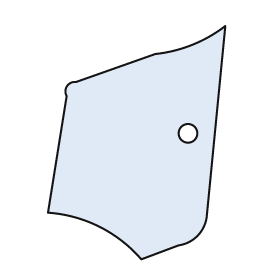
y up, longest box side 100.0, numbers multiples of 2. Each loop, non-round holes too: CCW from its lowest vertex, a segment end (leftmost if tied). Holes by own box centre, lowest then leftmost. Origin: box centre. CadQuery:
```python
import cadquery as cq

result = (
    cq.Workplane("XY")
    .moveTo(2.0, -50.0)
    .lineTo(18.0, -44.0)
    .threePointArc((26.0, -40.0), (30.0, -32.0))
    .lineTo(38.0, 50.0)
    .threePointArc((24.0, 42.0), (8.0, 38.0))
    .lineTo(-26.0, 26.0)
    .threePointArc((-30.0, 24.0), (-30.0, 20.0))
    .lineTo(-38.0, -30.0)
    .threePointArc((-16.0, -36.0), (2.0, -50.0))
    .close()
    .moveTo(22.0, 4.0)
    .circle(4.0)
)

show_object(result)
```